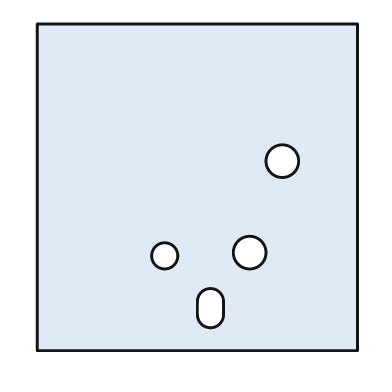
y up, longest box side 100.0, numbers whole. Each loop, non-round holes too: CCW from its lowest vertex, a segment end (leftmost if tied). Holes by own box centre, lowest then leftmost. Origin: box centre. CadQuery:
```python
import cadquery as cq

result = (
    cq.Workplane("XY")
    .moveTo(-49.0, -50.0)
    .lineTo(49.0, -50.0)
    .lineTo(49.0, 50.0)
    .lineTo(-49.0, 50.0)
    .close()
    .moveTo(0.0, -39.0)
    .threePointArc((4.0, -43.0), (8.0, -39.0))
    .lineTo(8.0, -35.0)
    .threePointArc((4.0, -31.0), (0.0, -35.0))
    .close()
    .moveTo(-10.0, -21.0)
    .circle(4.0)
    .moveTo(16.0, -20.0)
    .circle(5.0)
    .moveTo(26.0, 8.0)
    .circle(5.0)
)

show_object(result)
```